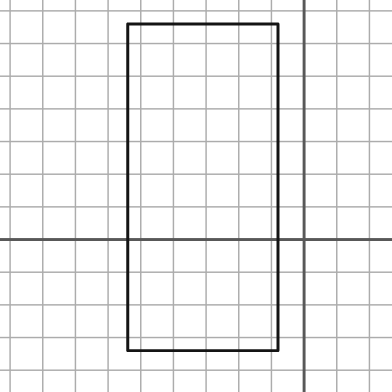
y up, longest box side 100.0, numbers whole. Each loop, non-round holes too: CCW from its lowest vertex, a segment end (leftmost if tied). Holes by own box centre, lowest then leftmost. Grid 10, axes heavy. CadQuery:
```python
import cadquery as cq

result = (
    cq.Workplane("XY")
    .moveTo(-54.0, -34.0)
    .lineTo(-8.0, -34.0)
    .lineTo(-8.0, 66.0)
    .lineTo(-54.0, 66.0)
    .close()
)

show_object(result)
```